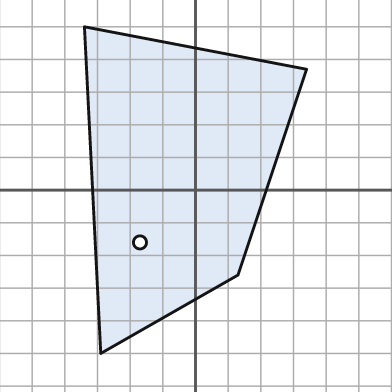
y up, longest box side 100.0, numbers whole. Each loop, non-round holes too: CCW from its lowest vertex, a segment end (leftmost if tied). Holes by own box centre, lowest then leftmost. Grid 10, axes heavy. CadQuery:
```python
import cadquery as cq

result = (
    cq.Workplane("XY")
    .moveTo(-29.0, -50.0)
    .lineTo(13.0, -26.0)
    .lineTo(34.0, 37.0)
    .lineTo(-34.0, 50.0)
    .close()
    .moveTo(-17.0, -16.0)
    .circle(2.0)
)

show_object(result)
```